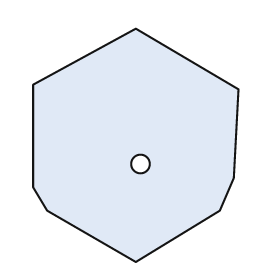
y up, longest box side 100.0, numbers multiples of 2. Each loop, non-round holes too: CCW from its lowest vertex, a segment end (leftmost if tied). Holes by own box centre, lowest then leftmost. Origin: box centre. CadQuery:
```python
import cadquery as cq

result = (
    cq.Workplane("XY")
    .moveTo(0.0, -50.0)
    .lineTo(36.0, -28.0)
    .lineTo(42.0, -14.0)
    .lineTo(44.0, 24.0)
    .lineTo(0.0, 50.0)
    .lineTo(-44.0, 26.0)
    .lineTo(-44.0, -18.0)
    .lineTo(-38.0, -28.0)
    .close()
    .moveTo(2.0, -8.0)
    .circle(4.0)
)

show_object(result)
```